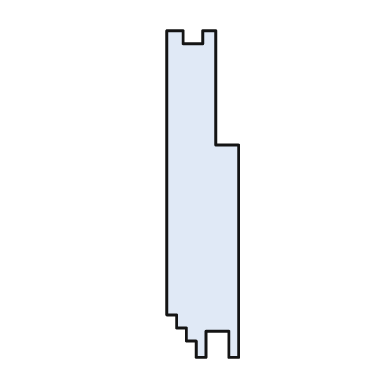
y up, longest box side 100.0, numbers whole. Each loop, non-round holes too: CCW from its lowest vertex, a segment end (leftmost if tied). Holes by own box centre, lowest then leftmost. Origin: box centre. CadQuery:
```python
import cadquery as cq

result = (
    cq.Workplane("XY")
    .moveTo(-2.0, -50.0)
    .lineTo(1.0, -50.0)
    .lineTo(1.0, -42.0)
    .lineTo(8.0, -42.0)
    .lineTo(8.0, -50.0)
    .lineTo(11.0, -50.0)
    .lineTo(11.0, 15.0)
    .lineTo(4.0, 15.0)
    .lineTo(4.0, 50.0)
    .lineTo(0.0, 50.0)
    .lineTo(0.0, 46.0)
    .lineTo(-6.0, 46.0)
    .lineTo(-6.0, 50.0)
    .lineTo(-11.0, 50.0)
    .lineTo(-11.0, -37.0)
    .lineTo(-8.0, -37.0)
    .lineTo(-8.0, -41.0)
    .lineTo(-5.0, -41.0)
    .lineTo(-5.0, -45.0)
    .lineTo(-2.0, -45.0)
    .close()
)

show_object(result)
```